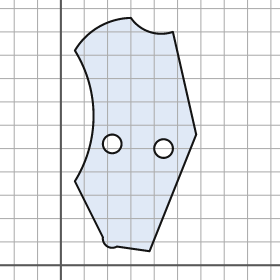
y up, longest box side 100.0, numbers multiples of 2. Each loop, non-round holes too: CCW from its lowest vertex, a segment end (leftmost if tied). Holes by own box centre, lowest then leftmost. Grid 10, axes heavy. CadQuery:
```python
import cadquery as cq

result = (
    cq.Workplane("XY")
    .moveTo(38.0, 6.0)
    .lineTo(58.0, 56.0)
    .lineTo(48.0, 100.0)
    .threePointArc((38.0, 100.0), (30.0, 106.0))
    .threePointArc((16.0, 102.0), (6.0, 92.0))
    .threePointArc((14.0, 64.0), (6.0, 36.0))
    .lineTo(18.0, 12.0)
    .threePointArc((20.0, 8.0), (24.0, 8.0))
    .close()
    .moveTo(44.0, 50.0)
    .circle(4.0)
    .moveTo(22.0, 52.0)
    .circle(4.0)
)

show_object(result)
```